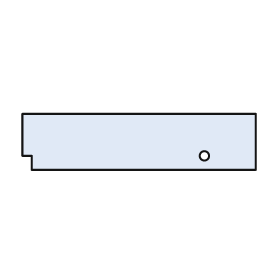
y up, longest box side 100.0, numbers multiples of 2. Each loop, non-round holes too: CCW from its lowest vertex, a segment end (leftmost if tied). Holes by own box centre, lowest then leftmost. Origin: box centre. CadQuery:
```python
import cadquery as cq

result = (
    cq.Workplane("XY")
    .moveTo(-46.0, -12.0)
    .lineTo(50.0, -12.0)
    .lineTo(50.0, 12.0)
    .lineTo(-50.0, 12.0)
    .lineTo(-50.0, -6.0)
    .lineTo(-46.0, -6.0)
    .close()
    .moveTo(28.0, -6.0)
    .circle(2.0)
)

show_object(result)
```